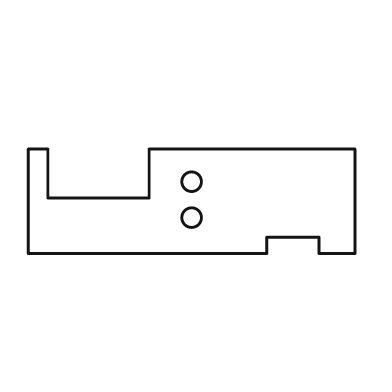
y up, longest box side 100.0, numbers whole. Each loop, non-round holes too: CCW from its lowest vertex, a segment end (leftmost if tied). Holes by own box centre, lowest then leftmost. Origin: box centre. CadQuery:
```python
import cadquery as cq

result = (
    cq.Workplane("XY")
    .moveTo(-50.0, -16.0)
    .lineTo(23.0, -16.0)
    .lineTo(23.0, -11.0)
    .lineTo(39.0, -11.0)
    .lineTo(39.0, -16.0)
    .lineTo(50.0, -16.0)
    .lineTo(50.0, 16.0)
    .lineTo(-13.0, 16.0)
    .lineTo(-13.0, 1.0)
    .lineTo(-44.0, 1.0)
    .lineTo(-44.0, 16.0)
    .lineTo(-50.0, 16.0)
    .close()
    .moveTo(0.0, -5.0)
    .circle(3.0)
    .moveTo(0.0, 6.0)
    .circle(3.0)
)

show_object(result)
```